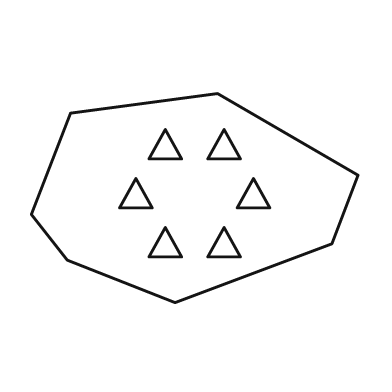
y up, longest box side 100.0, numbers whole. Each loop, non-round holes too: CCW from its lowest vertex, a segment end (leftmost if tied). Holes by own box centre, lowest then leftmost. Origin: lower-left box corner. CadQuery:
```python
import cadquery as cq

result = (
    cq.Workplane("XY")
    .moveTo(44.0, 0.0)
    .lineTo(92.0, 18.0)
    .lineTo(100.0, 39.0)
    .lineTo(57.0, 64.0)
    .lineTo(12.0, 58.0)
    .lineTo(0.0, 27.0)
    .lineTo(11.0, 13.0)
    .close()
    .moveTo(36.0, 14.0)
    .lineTo(46.0, 14.0)
    .lineTo(41.0, 23.0)
    .close()
    .moveTo(54.0, 14.0)
    .lineTo(64.0, 14.0)
    .lineTo(59.0, 23.0)
    .close()
    .moveTo(27.0, 29.0)
    .lineTo(37.0, 29.0)
    .lineTo(32.0, 38.0)
    .close()
    .moveTo(63.0, 29.0)
    .lineTo(73.0, 29.0)
    .lineTo(68.0, 38.0)
    .close()
    .moveTo(36.0, 44.0)
    .lineTo(46.0, 44.0)
    .lineTo(41.0, 53.0)
    .close()
    .moveTo(54.0, 44.0)
    .lineTo(64.0, 44.0)
    .lineTo(59.0, 53.0)
    .close()
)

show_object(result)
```